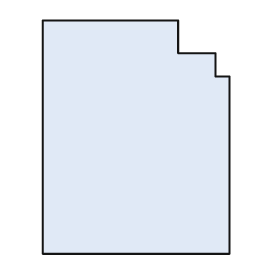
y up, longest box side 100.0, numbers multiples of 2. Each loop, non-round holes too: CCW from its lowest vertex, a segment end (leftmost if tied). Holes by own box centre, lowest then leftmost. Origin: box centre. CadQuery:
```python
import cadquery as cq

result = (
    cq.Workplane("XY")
    .moveTo(-40.0, -50.0)
    .lineTo(40.0, -50.0)
    .lineTo(40.0, 26.0)
    .lineTo(34.0, 26.0)
    .lineTo(34.0, 36.0)
    .lineTo(18.0, 36.0)
    .lineTo(18.0, 50.0)
    .lineTo(-40.0, 50.0)
    .close()
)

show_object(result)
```